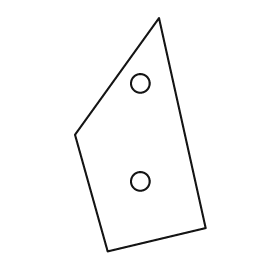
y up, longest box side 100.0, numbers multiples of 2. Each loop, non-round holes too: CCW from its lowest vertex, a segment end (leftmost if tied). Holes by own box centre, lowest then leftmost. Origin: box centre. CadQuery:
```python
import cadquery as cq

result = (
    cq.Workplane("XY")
    .moveTo(-14.0, -50.0)
    .lineTo(28.0, -40.0)
    .lineTo(8.0, 50.0)
    .lineTo(-28.0, 0.0)
    .close()
    .moveTo(0.0, -20.0)
    .circle(4.0)
    .moveTo(0.0, 22.0)
    .circle(4.0)
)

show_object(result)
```